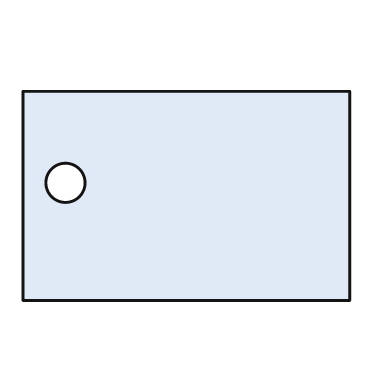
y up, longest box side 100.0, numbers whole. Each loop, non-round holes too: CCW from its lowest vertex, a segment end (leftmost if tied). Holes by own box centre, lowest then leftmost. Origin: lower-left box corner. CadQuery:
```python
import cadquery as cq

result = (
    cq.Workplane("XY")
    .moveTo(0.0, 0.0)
    .lineTo(100.0, 0.0)
    .lineTo(100.0, 64.0)
    .lineTo(0.0, 64.0)
    .close()
    .moveTo(13.0, 36.0)
    .circle(6.0)
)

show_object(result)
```